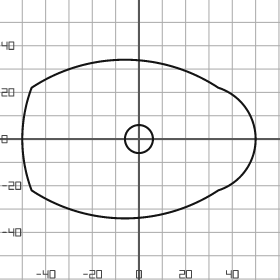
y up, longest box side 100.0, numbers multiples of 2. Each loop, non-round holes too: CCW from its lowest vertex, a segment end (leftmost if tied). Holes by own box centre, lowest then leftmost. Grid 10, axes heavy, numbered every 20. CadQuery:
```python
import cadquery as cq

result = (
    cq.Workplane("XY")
    .moveTo(-46.0, -22.0)
    .threePointArc((-6.0, -34.0), (34.0, -22.0))
    .threePointArc((50.0, 0.0), (34.0, 22.0))
    .threePointArc((-6.0, 34.0), (-46.0, 22.0))
    .threePointArc((-50.0, 0.0), (-46.0, -22.0))
    .close()
    .moveTo(0.0, 0.0)
    .circle(6.0)
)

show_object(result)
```